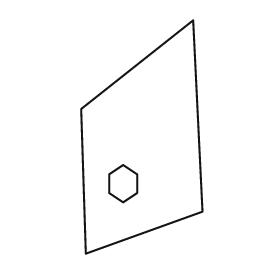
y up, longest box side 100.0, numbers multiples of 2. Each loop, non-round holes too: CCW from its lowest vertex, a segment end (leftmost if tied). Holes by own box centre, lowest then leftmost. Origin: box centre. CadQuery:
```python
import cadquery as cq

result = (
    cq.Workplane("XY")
    .moveTo(-24.0, -50.0)
    .lineTo(26.0, -32.0)
    .lineTo(22.0, 50.0)
    .lineTo(-26.0, 12.0)
    .close()
    .moveTo(-8.0, -28.0)
    .lineTo(-2.0, -24.0)
    .lineTo(-2.0, -16.0)
    .lineTo(-8.0, -12.0)
    .lineTo(-14.0, -16.0)
    .lineTo(-14.0, -24.0)
    .close()
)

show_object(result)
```